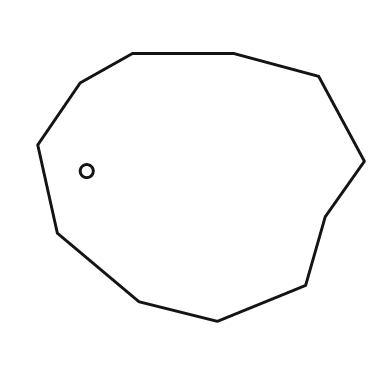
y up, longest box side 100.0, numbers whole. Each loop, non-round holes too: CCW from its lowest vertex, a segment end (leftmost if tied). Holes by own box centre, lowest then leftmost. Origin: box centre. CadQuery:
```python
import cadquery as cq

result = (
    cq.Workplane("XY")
    .moveTo(5.0, -41.0)
    .lineTo(32.0, -30.0)
    .lineTo(38.0, -9.0)
    .lineTo(50.0, 8.0)
    .lineTo(36.0, 34.0)
    .lineTo(10.0, 41.0)
    .lineTo(-21.0, 41.0)
    .lineTo(-37.0, 32.0)
    .lineTo(-50.0, 13.0)
    .lineTo(-44.0, -14.0)
    .lineTo(-19.0, -35.0)
    .close()
    .moveTo(-35.0, 5.0)
    .circle(2.0)
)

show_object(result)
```